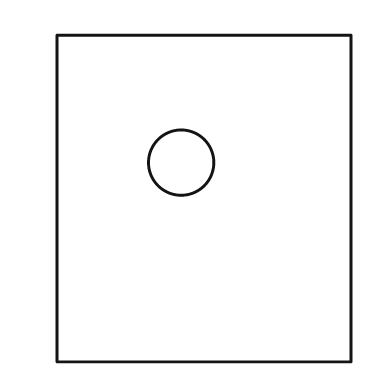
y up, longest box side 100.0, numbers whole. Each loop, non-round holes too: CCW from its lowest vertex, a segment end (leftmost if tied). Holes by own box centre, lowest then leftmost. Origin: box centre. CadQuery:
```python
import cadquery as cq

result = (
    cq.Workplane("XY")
    .moveTo(-45.0, -50.0)
    .lineTo(45.0, -50.0)
    .lineTo(45.0, 50.0)
    .lineTo(-45.0, 50.0)
    .close()
    .moveTo(-7.0, 11.0)
    .circle(10.0)
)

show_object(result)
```